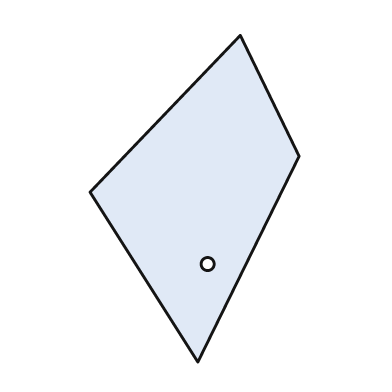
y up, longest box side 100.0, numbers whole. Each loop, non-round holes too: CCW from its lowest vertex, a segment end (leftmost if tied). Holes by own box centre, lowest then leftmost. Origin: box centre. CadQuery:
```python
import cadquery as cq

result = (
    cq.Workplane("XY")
    .moveTo(1.0, -50.0)
    .lineTo(32.0, 13.0)
    .lineTo(14.0, 50.0)
    .lineTo(-32.0, 2.0)
    .close()
    .moveTo(4.0, -20.0)
    .circle(2.0)
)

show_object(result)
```